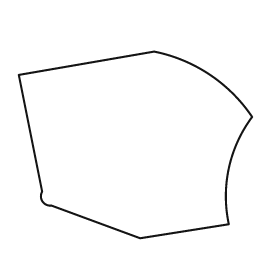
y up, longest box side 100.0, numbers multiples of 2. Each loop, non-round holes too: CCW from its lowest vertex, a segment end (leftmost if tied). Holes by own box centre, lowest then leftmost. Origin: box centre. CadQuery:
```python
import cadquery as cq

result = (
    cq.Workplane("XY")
    .moveTo(2.0, -40.0)
    .lineTo(40.0, -34.0)
    .threePointArc((40.0, -10.0), (50.0, 12.0))
    .threePointArc((32.0, 30.0), (8.0, 40.0))
    .lineTo(-50.0, 30.0)
    .lineTo(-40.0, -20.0)
    .threePointArc((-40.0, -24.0), (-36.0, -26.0))
    .close()
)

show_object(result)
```